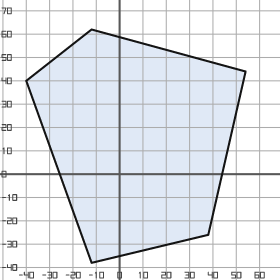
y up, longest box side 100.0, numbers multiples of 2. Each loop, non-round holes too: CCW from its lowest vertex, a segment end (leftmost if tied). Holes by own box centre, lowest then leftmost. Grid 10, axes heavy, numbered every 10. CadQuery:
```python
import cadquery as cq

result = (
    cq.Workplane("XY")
    .moveTo(-12.0, -38.0)
    .lineTo(38.0, -26.0)
    .lineTo(54.0, 44.0)
    .lineTo(-12.0, 62.0)
    .lineTo(-40.0, 40.0)
    .close()
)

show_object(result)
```